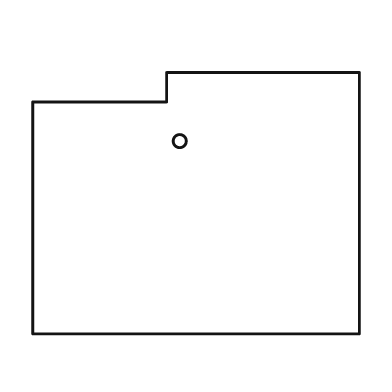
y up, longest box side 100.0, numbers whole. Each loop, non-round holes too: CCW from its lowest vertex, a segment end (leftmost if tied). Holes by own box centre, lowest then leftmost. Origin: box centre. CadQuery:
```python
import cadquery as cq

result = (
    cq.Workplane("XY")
    .moveTo(-50.0, -40.0)
    .lineTo(50.0, -40.0)
    .lineTo(50.0, 40.0)
    .lineTo(-9.0, 40.0)
    .lineTo(-9.0, 31.0)
    .lineTo(-50.0, 31.0)
    .close()
    .moveTo(-5.0, 19.0)
    .circle(2.0)
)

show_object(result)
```